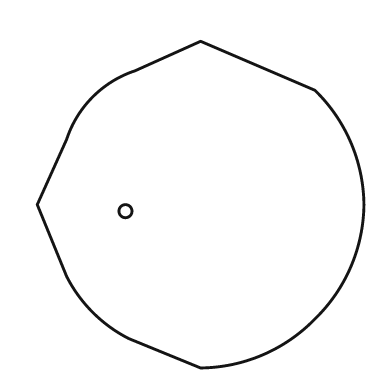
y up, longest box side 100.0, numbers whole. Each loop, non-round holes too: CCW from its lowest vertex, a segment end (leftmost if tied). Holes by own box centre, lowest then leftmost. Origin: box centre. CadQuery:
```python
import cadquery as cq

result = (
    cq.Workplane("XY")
    .moveTo(0.0, -50.0)
    .threePointArc((19.0, -46.0), (35.0, -35.0))
    .threePointArc((46.0, -19.0), (50.0, 0.0))
    .threePointArc((46.0, 19.0), (35.0, 35.0))
    .lineTo(0.0, 50.0)
    .lineTo(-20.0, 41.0)
    .threePointArc((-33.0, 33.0), (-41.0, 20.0))
    .lineTo(-50.0, 0.0)
    .lineTo(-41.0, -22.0)
    .threePointArc((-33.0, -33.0), (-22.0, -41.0))
    .close()
    .moveTo(-23.0, -2.0)
    .circle(2.0)
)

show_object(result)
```